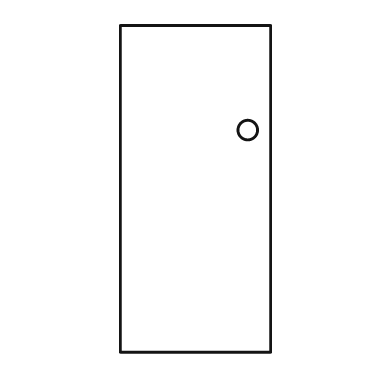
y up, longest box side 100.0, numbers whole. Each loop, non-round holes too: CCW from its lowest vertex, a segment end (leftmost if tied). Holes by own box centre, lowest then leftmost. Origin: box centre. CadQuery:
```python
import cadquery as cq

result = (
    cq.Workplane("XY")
    .moveTo(-23.0, -50.0)
    .lineTo(23.0, -50.0)
    .lineTo(23.0, 50.0)
    .lineTo(-23.0, 50.0)
    .close()
    .moveTo(16.0, 18.0)
    .circle(3.0)
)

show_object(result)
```